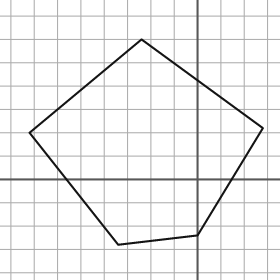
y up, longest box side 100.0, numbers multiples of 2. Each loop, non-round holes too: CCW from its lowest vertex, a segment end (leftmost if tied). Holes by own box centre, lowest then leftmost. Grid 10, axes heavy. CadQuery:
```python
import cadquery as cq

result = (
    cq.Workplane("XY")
    .moveTo(-34.0, -28.0)
    .lineTo(0.0, -24.0)
    .lineTo(28.0, 22.0)
    .lineTo(-24.0, 60.0)
    .lineTo(-72.0, 20.0)
    .close()
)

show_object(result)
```